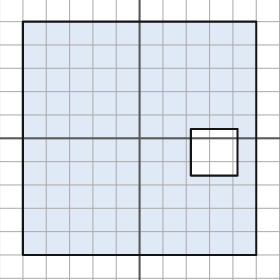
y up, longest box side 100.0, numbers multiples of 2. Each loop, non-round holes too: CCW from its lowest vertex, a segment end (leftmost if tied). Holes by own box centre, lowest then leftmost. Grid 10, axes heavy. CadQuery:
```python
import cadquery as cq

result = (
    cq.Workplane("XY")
    .moveTo(-50.0, -50.0)
    .lineTo(50.0, -50.0)
    .lineTo(50.0, 50.0)
    .lineTo(-50.0, 50.0)
    .close()
    .moveTo(22.0, -16.0)
    .lineTo(42.0, -16.0)
    .lineTo(42.0, 4.0)
    .lineTo(22.0, 4.0)
    .close()
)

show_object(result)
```